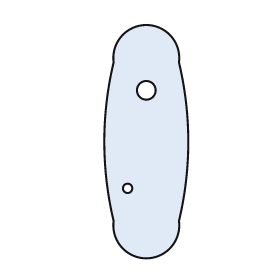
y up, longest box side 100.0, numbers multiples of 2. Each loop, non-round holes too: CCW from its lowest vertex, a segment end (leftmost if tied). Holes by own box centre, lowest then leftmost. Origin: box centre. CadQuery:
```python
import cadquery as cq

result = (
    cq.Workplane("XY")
    .moveTo(-14.0, -34.0)
    .threePointArc((0.0, -50.0), (14.0, -34.0))
    .threePointArc((18.0, 0.0), (14.0, 34.0))
    .threePointArc((0.0, 50.0), (-14.0, 34.0))
    .threePointArc((-18.0, 0.0), (-14.0, -34.0))
    .close()
    .moveTo(-8.0, -20.0)
    .circle(2.0)
    .moveTo(0.0, 22.0)
    .circle(4.0)
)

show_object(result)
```